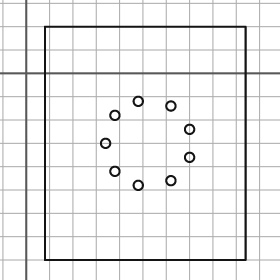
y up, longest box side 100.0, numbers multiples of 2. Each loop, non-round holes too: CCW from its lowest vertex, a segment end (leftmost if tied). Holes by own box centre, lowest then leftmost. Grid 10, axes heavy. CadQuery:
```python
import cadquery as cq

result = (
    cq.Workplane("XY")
    .moveTo(8.0, -80.0)
    .lineTo(94.0, -80.0)
    .lineTo(94.0, 20.0)
    .lineTo(8.0, 20.0)
    .close()
    .moveTo(48.0, -48.0)
    .circle(2.0)
    .moveTo(62.0, -46.0)
    .circle(2.0)
    .moveTo(38.0, -42.0)
    .circle(2.0)
    .moveTo(70.0, -36.0)
    .circle(2.0)
    .moveTo(34.0, -30.0)
    .circle(2.0)
    .moveTo(70.0, -24.0)
    .circle(2.0)
    .moveTo(38.0, -18.0)
    .circle(2.0)
    .moveTo(62.0, -14.0)
    .circle(2.0)
    .moveTo(48.0, -12.0)
    .circle(2.0)
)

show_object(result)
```